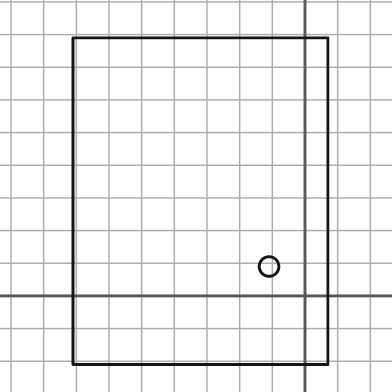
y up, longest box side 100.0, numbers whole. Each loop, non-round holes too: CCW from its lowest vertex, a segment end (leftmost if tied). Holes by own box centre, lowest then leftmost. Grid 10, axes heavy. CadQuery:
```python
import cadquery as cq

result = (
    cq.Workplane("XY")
    .moveTo(-71.0, -21.0)
    .lineTo(7.0, -21.0)
    .lineTo(7.0, 79.0)
    .lineTo(-71.0, 79.0)
    .close()
    .moveTo(-11.0, 9.0)
    .circle(3.0)
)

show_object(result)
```